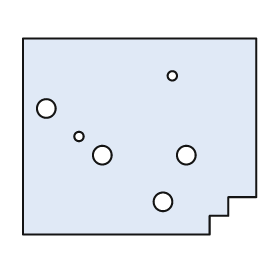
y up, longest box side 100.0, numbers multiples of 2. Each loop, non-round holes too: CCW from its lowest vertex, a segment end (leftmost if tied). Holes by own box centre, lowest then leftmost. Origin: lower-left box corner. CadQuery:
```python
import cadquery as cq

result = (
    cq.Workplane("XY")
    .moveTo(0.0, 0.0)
    .lineTo(80.0, 0.0)
    .lineTo(80.0, 8.0)
    .lineTo(88.0, 8.0)
    .lineTo(88.0, 16.0)
    .lineTo(100.0, 16.0)
    .lineTo(100.0, 84.0)
    .lineTo(0.0, 84.0)
    .close()
    .moveTo(60.0, 14.0)
    .circle(4.0)
    .moveTo(34.0, 34.0)
    .circle(4.0)
    .moveTo(70.0, 34.0)
    .circle(4.0)
    .moveTo(24.0, 42.0)
    .circle(2.0)
    .moveTo(10.0, 54.0)
    .circle(4.0)
    .moveTo(64.0, 68.0)
    .circle(2.0)
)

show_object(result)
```